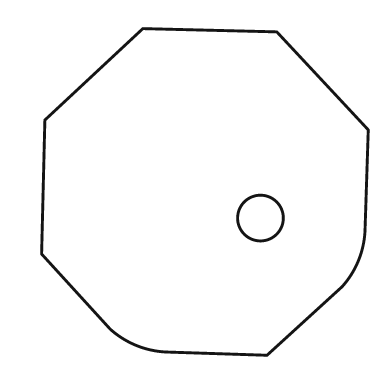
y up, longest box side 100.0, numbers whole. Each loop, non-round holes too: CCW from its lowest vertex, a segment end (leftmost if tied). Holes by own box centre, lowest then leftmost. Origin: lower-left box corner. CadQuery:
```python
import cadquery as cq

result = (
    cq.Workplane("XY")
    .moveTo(69.0, 0.0)
    .lineTo(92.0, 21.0)
    .threePointArc((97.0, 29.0), (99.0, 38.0))
    .lineTo(100.0, 69.0)
    .lineTo(72.0, 99.0)
    .lineTo(31.0, 100.0)
    .lineTo(1.0, 72.0)
    .lineTo(0.0, 31.0)
    .lineTo(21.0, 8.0)
    .threePointArc((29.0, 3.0), (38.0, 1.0))
    .close()
    .moveTo(67.0, 42.0)
    .circle(7.0)
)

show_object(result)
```